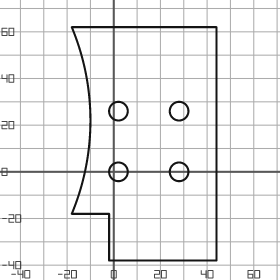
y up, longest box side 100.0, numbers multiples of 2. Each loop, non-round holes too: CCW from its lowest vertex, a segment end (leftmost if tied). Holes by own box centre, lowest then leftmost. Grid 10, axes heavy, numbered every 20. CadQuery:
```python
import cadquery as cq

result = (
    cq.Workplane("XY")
    .moveTo(-2.0, -38.0)
    .lineTo(44.0, -38.0)
    .lineTo(44.0, 62.0)
    .lineTo(-18.0, 62.0)
    .threePointArc((-10.0, 22.0), (-18.0, -18.0))
    .lineTo(-2.0, -18.0)
    .close()
    .moveTo(2.0, 0.0)
    .circle(4.0)
    .moveTo(28.0, 0.0)
    .circle(4.0)
    .moveTo(2.0, 26.0)
    .circle(4.0)
    .moveTo(28.0, 26.0)
    .circle(4.0)
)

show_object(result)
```